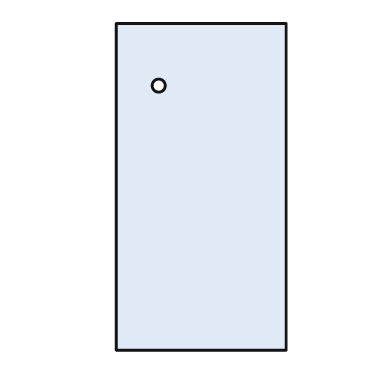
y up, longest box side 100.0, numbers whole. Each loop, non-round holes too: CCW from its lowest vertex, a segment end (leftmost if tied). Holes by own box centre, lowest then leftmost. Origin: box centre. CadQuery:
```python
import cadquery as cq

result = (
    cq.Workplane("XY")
    .moveTo(-26.0, -50.0)
    .lineTo(26.0, -50.0)
    .lineTo(26.0, 50.0)
    .lineTo(-26.0, 50.0)
    .close()
    .moveTo(-13.0, 31.0)
    .circle(2.0)
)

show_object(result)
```